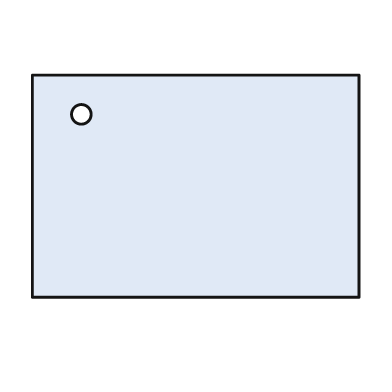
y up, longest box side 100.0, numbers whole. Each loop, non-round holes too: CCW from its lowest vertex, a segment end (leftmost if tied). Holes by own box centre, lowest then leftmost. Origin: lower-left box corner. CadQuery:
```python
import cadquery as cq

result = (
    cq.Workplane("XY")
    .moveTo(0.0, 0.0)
    .lineTo(100.0, 0.0)
    .lineTo(100.0, 68.0)
    .lineTo(0.0, 68.0)
    .close()
    .moveTo(15.0, 56.0)
    .circle(3.0)
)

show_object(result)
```